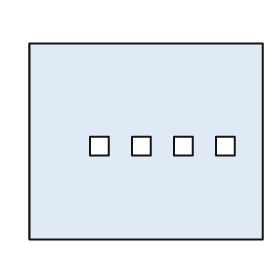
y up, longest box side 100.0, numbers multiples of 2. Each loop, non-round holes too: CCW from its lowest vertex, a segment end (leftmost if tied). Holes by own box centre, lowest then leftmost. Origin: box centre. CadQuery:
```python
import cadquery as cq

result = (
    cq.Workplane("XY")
    .moveTo(-50.0, -42.0)
    .lineTo(50.0, -42.0)
    .lineTo(50.0, 42.0)
    .lineTo(-50.0, 42.0)
    .close()
    .moveTo(-24.0, -6.0)
    .lineTo(-16.0, -6.0)
    .lineTo(-16.0, 2.0)
    .lineTo(-24.0, 2.0)
    .close()
    .moveTo(-6.0, -6.0)
    .lineTo(2.0, -6.0)
    .lineTo(2.0, 2.0)
    .lineTo(-6.0, 2.0)
    .close()
    .moveTo(12.0, -6.0)
    .lineTo(20.0, -6.0)
    .lineTo(20.0, 2.0)
    .lineTo(12.0, 2.0)
    .close()
    .moveTo(30.0, -6.0)
    .lineTo(38.0, -6.0)
    .lineTo(38.0, 2.0)
    .lineTo(30.0, 2.0)
    .close()
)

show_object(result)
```